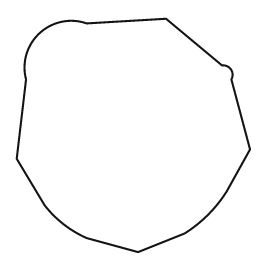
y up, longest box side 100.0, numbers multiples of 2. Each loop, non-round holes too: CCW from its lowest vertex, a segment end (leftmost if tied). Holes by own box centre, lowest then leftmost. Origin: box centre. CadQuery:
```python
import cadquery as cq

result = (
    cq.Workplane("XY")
    .moveTo(2.0, -50.0)
    .lineTo(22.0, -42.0)
    .threePointArc((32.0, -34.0), (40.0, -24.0))
    .lineTo(50.0, -6.0)
    .lineTo(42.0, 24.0)
    .threePointArc((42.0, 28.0), (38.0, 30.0))
    .lineTo(14.0, 50.0)
    .lineTo(-20.0, 48.0)
    .threePointArc((-40.0, 44.0), (-46.0, 24.0))
    .lineTo(-50.0, -10.0)
    .lineTo(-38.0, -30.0)
    .threePointArc((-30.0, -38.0), (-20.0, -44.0))
    .close()
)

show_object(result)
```